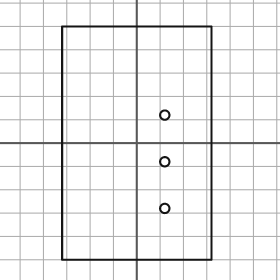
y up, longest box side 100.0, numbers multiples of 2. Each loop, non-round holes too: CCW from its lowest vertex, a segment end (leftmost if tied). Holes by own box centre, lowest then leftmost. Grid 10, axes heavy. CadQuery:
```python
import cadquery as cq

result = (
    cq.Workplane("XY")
    .moveTo(-32.0, -50.0)
    .lineTo(32.0, -50.0)
    .lineTo(32.0, 50.0)
    .lineTo(-32.0, 50.0)
    .close()
    .moveTo(12.0, -28.0)
    .circle(2.0)
    .moveTo(12.0, -8.0)
    .circle(2.0)
    .moveTo(12.0, 12.0)
    .circle(2.0)
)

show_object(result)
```